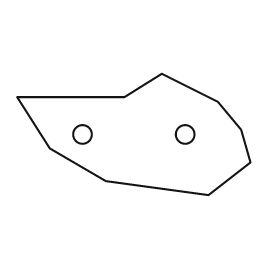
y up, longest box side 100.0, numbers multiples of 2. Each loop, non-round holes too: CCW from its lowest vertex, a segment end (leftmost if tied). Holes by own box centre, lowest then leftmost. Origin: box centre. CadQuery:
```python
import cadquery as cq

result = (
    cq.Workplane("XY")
    .moveTo(32.0, -26.0)
    .lineTo(50.0, -12.0)
    .lineTo(46.0, 2.0)
    .lineTo(36.0, 14.0)
    .lineTo(12.0, 26.0)
    .lineTo(-4.0, 16.0)
    .lineTo(-50.0, 16.0)
    .lineTo(-36.0, -6.0)
    .lineTo(-12.0, -20.0)
    .close()
    .moveTo(-22.0, 0.0)
    .circle(4.0)
    .moveTo(22.0, 0.0)
    .circle(4.0)
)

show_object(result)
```